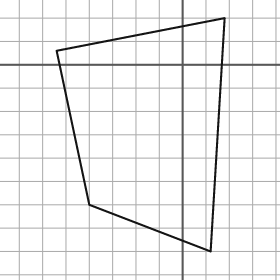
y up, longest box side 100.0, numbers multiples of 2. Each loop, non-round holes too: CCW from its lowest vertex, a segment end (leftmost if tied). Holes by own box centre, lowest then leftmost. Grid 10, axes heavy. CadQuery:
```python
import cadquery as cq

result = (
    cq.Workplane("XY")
    .moveTo(12.0, -80.0)
    .lineTo(18.0, 20.0)
    .lineTo(-54.0, 6.0)
    .lineTo(-40.0, -60.0)
    .close()
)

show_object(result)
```